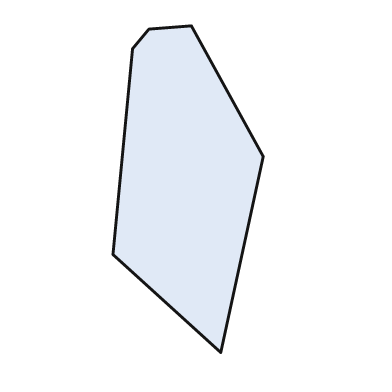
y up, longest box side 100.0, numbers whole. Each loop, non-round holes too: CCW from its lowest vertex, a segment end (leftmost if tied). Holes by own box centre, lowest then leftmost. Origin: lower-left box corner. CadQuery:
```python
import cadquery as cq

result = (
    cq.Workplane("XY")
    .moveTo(33.0, 0.0)
    .lineTo(46.0, 60.0)
    .lineTo(24.0, 100.0)
    .lineTo(11.0, 99.0)
    .lineTo(6.0, 93.0)
    .lineTo(0.0, 30.0)
    .close()
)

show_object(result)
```